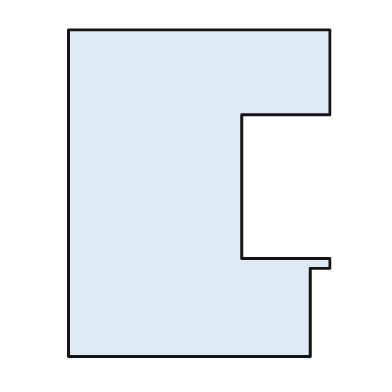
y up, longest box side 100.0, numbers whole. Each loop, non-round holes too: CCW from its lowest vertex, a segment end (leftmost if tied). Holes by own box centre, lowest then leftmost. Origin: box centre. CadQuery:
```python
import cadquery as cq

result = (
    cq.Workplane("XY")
    .moveTo(-40.0, -50.0)
    .lineTo(34.0, -50.0)
    .lineTo(34.0, -23.0)
    .lineTo(40.0, -23.0)
    .lineTo(40.0, -20.0)
    .lineTo(13.0, -20.0)
    .lineTo(13.0, 24.0)
    .lineTo(40.0, 24.0)
    .lineTo(40.0, 50.0)
    .lineTo(-40.0, 50.0)
    .close()
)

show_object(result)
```